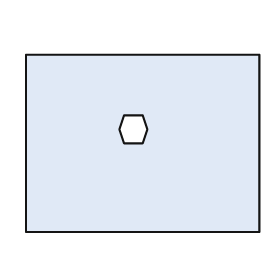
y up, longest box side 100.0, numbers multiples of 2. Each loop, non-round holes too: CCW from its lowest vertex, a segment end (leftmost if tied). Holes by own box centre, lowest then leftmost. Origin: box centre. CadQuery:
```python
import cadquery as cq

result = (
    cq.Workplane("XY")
    .moveTo(-50.0, -38.0)
    .lineTo(50.0, -38.0)
    .lineTo(50.0, 38.0)
    .lineTo(-50.0, 38.0)
    .close()
    .moveTo(-8.0, 0.0)
    .lineTo(0.0, 0.0)
    .lineTo(2.0, 6.0)
    .lineTo(0.0, 12.0)
    .lineTo(-8.0, 12.0)
    .lineTo(-10.0, 6.0)
    .close()
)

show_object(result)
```